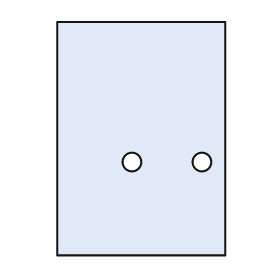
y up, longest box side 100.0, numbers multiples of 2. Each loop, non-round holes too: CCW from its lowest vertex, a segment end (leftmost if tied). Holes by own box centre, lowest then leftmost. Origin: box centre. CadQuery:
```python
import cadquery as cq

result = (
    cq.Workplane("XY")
    .moveTo(-36.0, -50.0)
    .lineTo(36.0, -50.0)
    .lineTo(36.0, 50.0)
    .lineTo(-36.0, 50.0)
    .close()
    .moveTo(-4.0, -10.0)
    .circle(4.0)
    .moveTo(26.0, -10.0)
    .circle(4.0)
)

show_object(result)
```